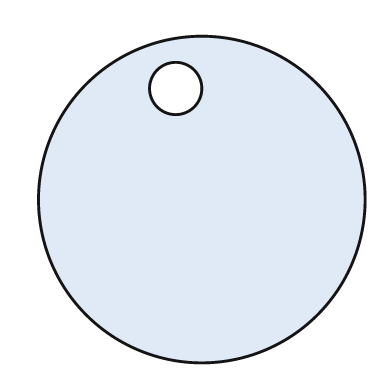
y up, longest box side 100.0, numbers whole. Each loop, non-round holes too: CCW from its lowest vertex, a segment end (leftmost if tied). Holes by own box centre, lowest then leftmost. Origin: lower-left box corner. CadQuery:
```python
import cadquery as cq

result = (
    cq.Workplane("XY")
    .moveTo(50.0, 50.0)
    .circle(50.0)
    .moveTo(42.0, 84.0)
    .circle(8.0)
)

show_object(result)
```